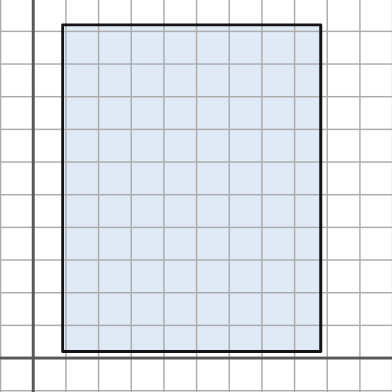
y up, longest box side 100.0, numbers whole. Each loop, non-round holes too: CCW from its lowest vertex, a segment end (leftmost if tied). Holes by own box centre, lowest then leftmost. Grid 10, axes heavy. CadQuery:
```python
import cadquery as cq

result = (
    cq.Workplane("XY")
    .moveTo(9.0, 2.0)
    .lineTo(88.0, 2.0)
    .lineTo(88.0, 102.0)
    .lineTo(9.0, 102.0)
    .close()
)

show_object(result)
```